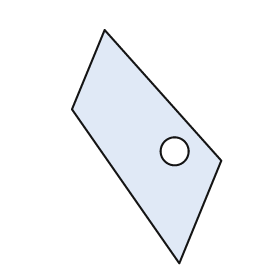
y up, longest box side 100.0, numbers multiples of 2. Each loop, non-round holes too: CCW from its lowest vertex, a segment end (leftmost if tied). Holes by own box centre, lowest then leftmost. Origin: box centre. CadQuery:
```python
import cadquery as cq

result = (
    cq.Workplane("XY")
    .moveTo(14.0, -50.0)
    .lineTo(32.0, -6.0)
    .lineTo(-18.0, 50.0)
    .lineTo(-32.0, 16.0)
    .close()
    .moveTo(12.0, -2.0)
    .circle(6.0)
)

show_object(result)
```